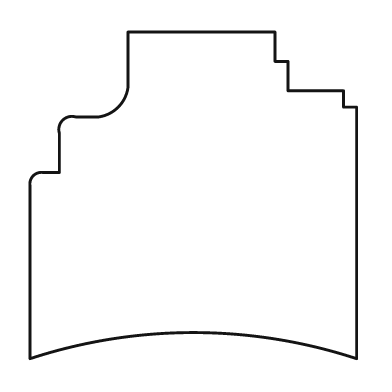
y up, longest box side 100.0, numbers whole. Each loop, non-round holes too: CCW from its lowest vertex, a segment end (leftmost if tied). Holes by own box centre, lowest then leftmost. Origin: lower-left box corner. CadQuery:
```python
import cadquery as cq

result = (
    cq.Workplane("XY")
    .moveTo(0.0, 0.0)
    .threePointArc((50.0, 8.0), (100.0, 0.0))
    .lineTo(100.0, 77.0)
    .lineTo(96.0, 77.0)
    .lineTo(96.0, 82.0)
    .lineTo(79.0, 82.0)
    .lineTo(79.0, 91.0)
    .lineTo(75.0, 91.0)
    .lineTo(75.0, 100.0)
    .lineTo(30.0, 100.0)
    .lineTo(30.0, 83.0)
    .threePointArc((27.0, 77.0), (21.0, 74.0))
    .lineTo(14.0, 74.0)
    .threePointArc((10.0, 73.0), (9.0, 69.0))
    .lineTo(9.0, 57.0)
    .lineTo(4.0, 57.0)
    .threePointArc((1.0, 56.0), (0.0, 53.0))
    .close()
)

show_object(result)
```